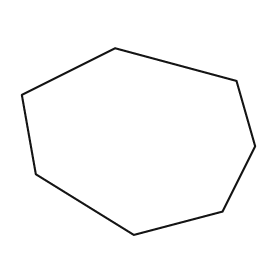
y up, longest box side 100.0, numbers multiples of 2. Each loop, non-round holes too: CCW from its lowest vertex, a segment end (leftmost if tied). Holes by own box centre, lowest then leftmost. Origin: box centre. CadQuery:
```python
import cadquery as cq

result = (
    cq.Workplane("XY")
    .moveTo(-2.0, -40.0)
    .lineTo(36.0, -30.0)
    .lineTo(50.0, -2.0)
    .lineTo(42.0, 26.0)
    .lineTo(-10.0, 40.0)
    .lineTo(-50.0, 20.0)
    .lineTo(-44.0, -14.0)
    .close()
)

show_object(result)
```